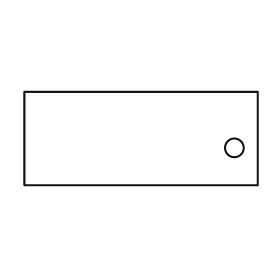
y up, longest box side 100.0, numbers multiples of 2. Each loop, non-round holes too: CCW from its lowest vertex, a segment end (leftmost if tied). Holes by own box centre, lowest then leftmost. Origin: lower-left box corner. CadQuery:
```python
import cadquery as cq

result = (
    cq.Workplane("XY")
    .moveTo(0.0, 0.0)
    .lineTo(100.0, 0.0)
    .lineTo(100.0, 40.0)
    .lineTo(0.0, 40.0)
    .close()
    .moveTo(90.0, 16.0)
    .circle(4.0)
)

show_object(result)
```